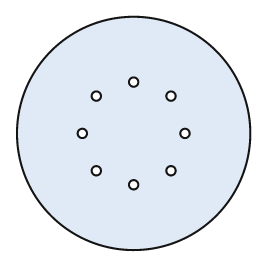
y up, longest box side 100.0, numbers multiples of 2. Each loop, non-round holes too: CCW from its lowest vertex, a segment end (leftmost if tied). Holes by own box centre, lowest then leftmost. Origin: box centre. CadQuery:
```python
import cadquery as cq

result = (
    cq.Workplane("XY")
    .moveTo(0.0, 0.0)
    .circle(50.0)
    .moveTo(0.0, -22.0)
    .circle(2.0)
    .moveTo(-16.0, -16.0)
    .circle(2.0)
    .moveTo(16.0, -16.0)
    .circle(2.0)
    .moveTo(-22.0, 0.0)
    .circle(2.0)
    .moveTo(22.0, 0.0)
    .circle(2.0)
    .moveTo(-16.0, 16.0)
    .circle(2.0)
    .moveTo(16.0, 16.0)
    .circle(2.0)
    .moveTo(0.0, 22.0)
    .circle(2.0)
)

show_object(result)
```